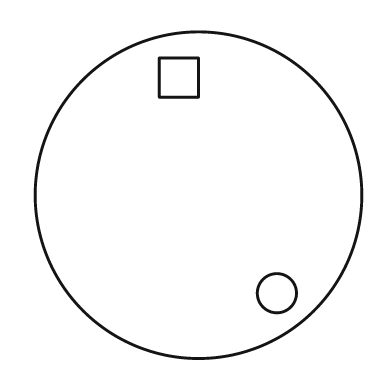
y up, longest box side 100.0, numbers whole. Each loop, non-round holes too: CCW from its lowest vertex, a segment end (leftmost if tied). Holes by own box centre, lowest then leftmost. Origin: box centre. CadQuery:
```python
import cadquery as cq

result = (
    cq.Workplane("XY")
    .moveTo(0.0, 0.0)
    .circle(50.0)
    .moveTo(24.0, -30.0)
    .circle(6.0)
    .moveTo(-12.0, 30.0)
    .lineTo(0.0, 30.0)
    .lineTo(0.0, 42.0)
    .lineTo(-12.0, 42.0)
    .close()
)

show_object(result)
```